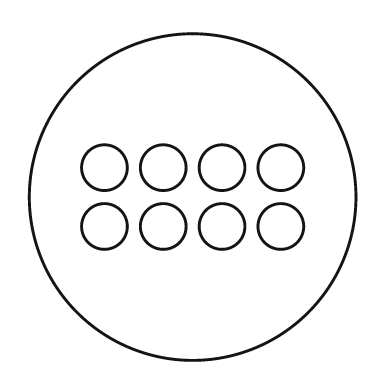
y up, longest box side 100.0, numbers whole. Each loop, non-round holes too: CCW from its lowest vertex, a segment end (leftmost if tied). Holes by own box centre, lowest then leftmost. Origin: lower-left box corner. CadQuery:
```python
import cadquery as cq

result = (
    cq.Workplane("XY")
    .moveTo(50.0, 50.0)
    .circle(50.0)
    .moveTo(23.0, 41.0)
    .circle(7.0)
    .moveTo(41.0, 41.0)
    .circle(7.0)
    .moveTo(59.0, 41.0)
    .circle(7.0)
    .moveTo(77.0, 41.0)
    .circle(7.0)
    .moveTo(23.0, 59.0)
    .circle(7.0)
    .moveTo(41.0, 59.0)
    .circle(7.0)
    .moveTo(59.0, 59.0)
    .circle(7.0)
    .moveTo(77.0, 59.0)
    .circle(7.0)
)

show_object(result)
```